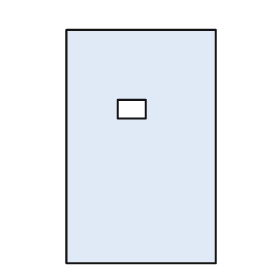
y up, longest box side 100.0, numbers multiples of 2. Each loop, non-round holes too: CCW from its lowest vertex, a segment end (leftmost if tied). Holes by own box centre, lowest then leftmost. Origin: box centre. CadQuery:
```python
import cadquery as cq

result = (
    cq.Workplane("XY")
    .moveTo(-32.0, -50.0)
    .lineTo(32.0, -50.0)
    .lineTo(32.0, 50.0)
    .lineTo(-32.0, 50.0)
    .close()
    .moveTo(-10.0, 12.0)
    .lineTo(2.0, 12.0)
    .lineTo(2.0, 20.0)
    .lineTo(-10.0, 20.0)
    .close()
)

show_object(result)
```